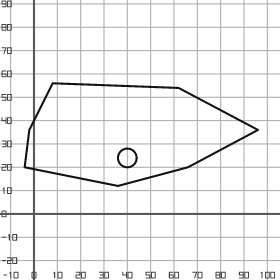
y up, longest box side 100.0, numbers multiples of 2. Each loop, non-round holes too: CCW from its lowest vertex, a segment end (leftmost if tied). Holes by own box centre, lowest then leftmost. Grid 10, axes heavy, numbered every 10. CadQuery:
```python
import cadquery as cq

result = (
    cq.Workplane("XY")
    .moveTo(36.0, 12.0)
    .lineTo(66.0, 20.0)
    .lineTo(96.0, 36.0)
    .lineTo(62.0, 54.0)
    .lineTo(8.0, 56.0)
    .lineTo(-2.0, 36.0)
    .lineTo(-4.0, 20.0)
    .close()
    .moveTo(40.0, 24.0)
    .circle(4.0)
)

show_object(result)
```